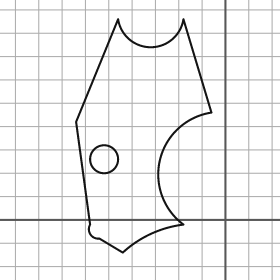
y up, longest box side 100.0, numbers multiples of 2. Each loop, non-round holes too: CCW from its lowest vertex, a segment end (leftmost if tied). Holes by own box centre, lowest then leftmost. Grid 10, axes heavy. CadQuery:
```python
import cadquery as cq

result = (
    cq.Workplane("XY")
    .moveTo(-44.0, -14.0)
    .threePointArc((-32.0, -6.0), (-18.0, -2.0))
    .threePointArc((-28.0, 26.0), (-6.0, 46.0))
    .lineTo(-18.0, 86.0)
    .threePointArc((-32.0, 74.0), (-46.0, 86.0))
    .lineTo(-64.0, 42.0)
    .lineTo(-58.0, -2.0)
    .threePointArc((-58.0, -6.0), (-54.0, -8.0))
    .close()
    .moveTo(-52.0, 26.0)
    .circle(6.0)
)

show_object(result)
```